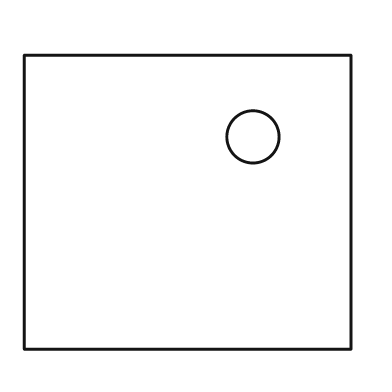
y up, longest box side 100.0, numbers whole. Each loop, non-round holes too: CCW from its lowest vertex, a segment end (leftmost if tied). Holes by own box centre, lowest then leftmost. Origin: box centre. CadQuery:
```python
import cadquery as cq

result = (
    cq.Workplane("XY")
    .moveTo(-50.0, -45.0)
    .lineTo(50.0, -45.0)
    .lineTo(50.0, 45.0)
    .lineTo(-50.0, 45.0)
    .close()
    .moveTo(20.0, 20.0)
    .circle(8.0)
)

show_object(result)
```